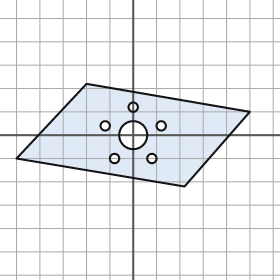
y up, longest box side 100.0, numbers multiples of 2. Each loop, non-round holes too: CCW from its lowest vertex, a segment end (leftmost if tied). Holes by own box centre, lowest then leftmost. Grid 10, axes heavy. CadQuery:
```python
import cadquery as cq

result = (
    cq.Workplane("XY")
    .moveTo(22.0, -22.0)
    .lineTo(50.0, 10.0)
    .lineTo(-20.0, 22.0)
    .lineTo(-50.0, -10.0)
    .close()
    .moveTo(-8.0, -10.0)
    .circle(2.0)
    .moveTo(8.0, -10.0)
    .circle(2.0)
    .moveTo(0.0, 0.0)
    .circle(6.0)
    .moveTo(-12.0, 4.0)
    .circle(2.0)
    .moveTo(12.0, 4.0)
    .circle(2.0)
    .moveTo(0.0, 12.0)
    .circle(2.0)
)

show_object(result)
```